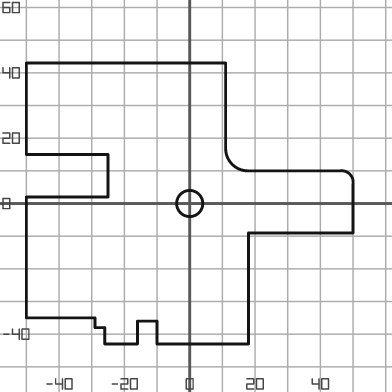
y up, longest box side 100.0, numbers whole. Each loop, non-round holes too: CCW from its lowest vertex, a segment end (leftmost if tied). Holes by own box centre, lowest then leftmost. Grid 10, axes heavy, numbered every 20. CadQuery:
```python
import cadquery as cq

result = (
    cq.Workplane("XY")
    .moveTo(-26.0, -43.0)
    .lineTo(-16.0, -43.0)
    .lineTo(-16.0, -36.0)
    .lineTo(-10.0, -36.0)
    .lineTo(-10.0, -43.0)
    .lineTo(18.0, -43.0)
    .lineTo(18.0, -9.0)
    .lineTo(50.0, -9.0)
    .lineTo(50.0, 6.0)
    .threePointArc((49.0, 9.0), (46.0, 10.0))
    .lineTo(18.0, 10.0)
    .threePointArc((13.0, 12.0), (11.0, 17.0))
    .lineTo(11.0, 43.0)
    .lineTo(-50.0, 43.0)
    .lineTo(-50.0, 15.0)
    .lineTo(-25.0, 15.0)
    .lineTo(-25.0, 2.0)
    .lineTo(-50.0, 2.0)
    .lineTo(-50.0, -35.0)
    .lineTo(-29.0, -35.0)
    .lineTo(-29.0, -38.0)
    .lineTo(-26.0, -38.0)
    .close()
    .moveTo(0.0, 0.0)
    .circle(4.0)
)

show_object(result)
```